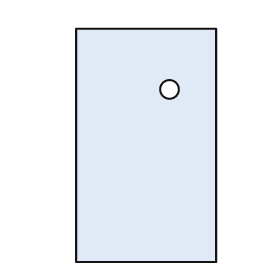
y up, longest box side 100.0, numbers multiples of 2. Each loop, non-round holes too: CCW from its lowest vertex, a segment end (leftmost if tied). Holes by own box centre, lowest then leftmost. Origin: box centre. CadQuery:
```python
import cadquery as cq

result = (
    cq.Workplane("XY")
    .moveTo(-30.0, -50.0)
    .lineTo(30.0, -50.0)
    .lineTo(30.0, 50.0)
    .lineTo(-30.0, 50.0)
    .close()
    .moveTo(10.0, 24.0)
    .circle(4.0)
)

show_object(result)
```